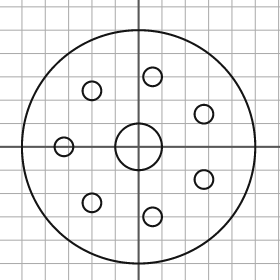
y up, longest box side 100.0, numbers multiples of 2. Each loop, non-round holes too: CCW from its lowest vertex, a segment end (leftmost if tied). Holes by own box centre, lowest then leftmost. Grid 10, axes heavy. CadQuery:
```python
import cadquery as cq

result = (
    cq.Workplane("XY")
    .moveTo(0.0, 0.0)
    .circle(50.0)
    .moveTo(6.0, -30.0)
    .circle(4.0)
    .moveTo(-20.0, -24.0)
    .circle(4.0)
    .moveTo(28.0, -14.0)
    .circle(4.0)
    .moveTo(-32.0, 0.0)
    .circle(4.0)
    .moveTo(0.0, 0.0)
    .circle(10.0)
    .moveTo(28.0, 14.0)
    .circle(4.0)
    .moveTo(-20.0, 24.0)
    .circle(4.0)
    .moveTo(6.0, 30.0)
    .circle(4.0)
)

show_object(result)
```